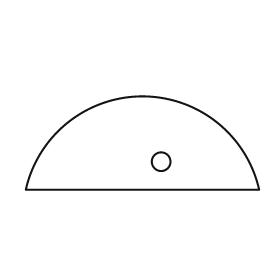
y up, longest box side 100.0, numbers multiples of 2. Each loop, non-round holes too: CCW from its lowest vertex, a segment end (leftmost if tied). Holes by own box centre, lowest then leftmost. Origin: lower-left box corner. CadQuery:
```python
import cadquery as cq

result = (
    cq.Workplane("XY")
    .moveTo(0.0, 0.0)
    .lineTo(100.0, 0.0)
    .threePointArc((50.0, 40.0), (0.0, 0.0))
    .close()
    .moveTo(58.0, 12.0)
    .circle(4.0)
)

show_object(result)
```